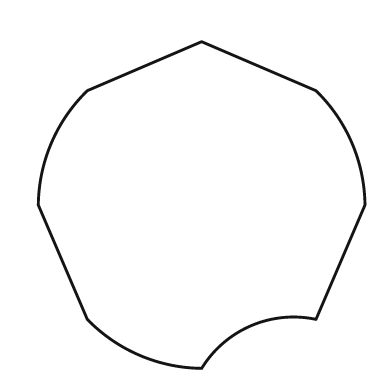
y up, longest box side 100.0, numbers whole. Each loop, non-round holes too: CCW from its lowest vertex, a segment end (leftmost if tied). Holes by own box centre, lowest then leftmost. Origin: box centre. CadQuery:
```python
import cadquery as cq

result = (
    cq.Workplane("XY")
    .moveTo(0.0, -50.0)
    .threePointArc((15.0, -37.0), (35.0, -35.0))
    .lineTo(50.0, 0.0)
    .threePointArc((46.0, 19.0), (35.0, 35.0))
    .lineTo(0.0, 50.0)
    .lineTo(-35.0, 35.0)
    .threePointArc((-46.0, 19.0), (-50.0, 0.0))
    .lineTo(-35.0, -35.0)
    .threePointArc((-19.0, -46.0), (0.0, -50.0))
    .close()
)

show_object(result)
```